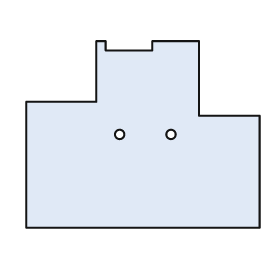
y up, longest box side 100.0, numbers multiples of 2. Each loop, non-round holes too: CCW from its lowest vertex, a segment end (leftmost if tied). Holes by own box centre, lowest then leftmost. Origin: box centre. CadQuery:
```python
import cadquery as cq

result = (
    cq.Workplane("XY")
    .moveTo(-50.0, -40.0)
    .lineTo(50.0, -40.0)
    .lineTo(50.0, 8.0)
    .lineTo(24.0, 8.0)
    .lineTo(24.0, 40.0)
    .lineTo(4.0, 40.0)
    .lineTo(4.0, 36.0)
    .lineTo(-16.0, 36.0)
    .lineTo(-16.0, 40.0)
    .lineTo(-20.0, 40.0)
    .lineTo(-20.0, 14.0)
    .lineTo(-50.0, 14.0)
    .close()
    .moveTo(-10.0, 0.0)
    .circle(2.0)
    .moveTo(12.0, 0.0)
    .circle(2.0)
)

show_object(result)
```